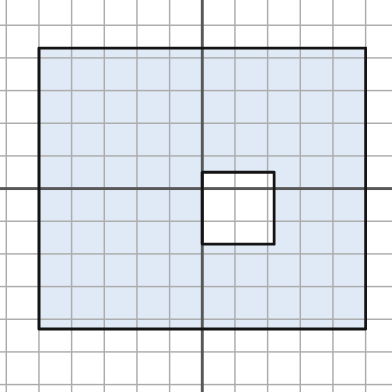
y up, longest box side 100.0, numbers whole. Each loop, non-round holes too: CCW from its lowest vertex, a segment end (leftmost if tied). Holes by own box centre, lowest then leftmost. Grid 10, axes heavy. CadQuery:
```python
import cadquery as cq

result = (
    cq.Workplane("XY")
    .moveTo(-50.0, -43.0)
    .lineTo(50.0, -43.0)
    .lineTo(50.0, 43.0)
    .lineTo(-50.0, 43.0)
    .close()
    .moveTo(0.0, -17.0)
    .lineTo(22.0, -17.0)
    .lineTo(22.0, 5.0)
    .lineTo(0.0, 5.0)
    .close()
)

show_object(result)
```